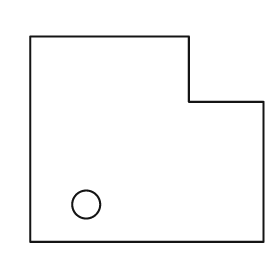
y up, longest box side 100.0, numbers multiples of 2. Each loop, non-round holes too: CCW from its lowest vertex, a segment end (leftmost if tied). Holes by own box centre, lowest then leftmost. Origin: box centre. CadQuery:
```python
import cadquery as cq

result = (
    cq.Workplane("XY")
    .moveTo(-50.0, -44.0)
    .lineTo(50.0, -44.0)
    .lineTo(50.0, 16.0)
    .lineTo(18.0, 16.0)
    .lineTo(18.0, 44.0)
    .lineTo(-50.0, 44.0)
    .close()
    .moveTo(-26.0, -28.0)
    .circle(6.0)
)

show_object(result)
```